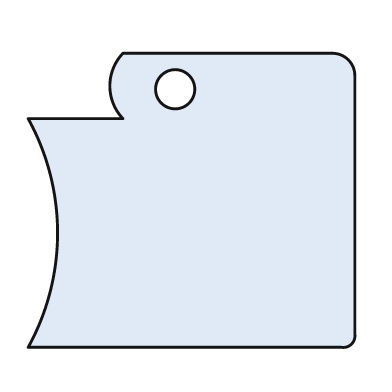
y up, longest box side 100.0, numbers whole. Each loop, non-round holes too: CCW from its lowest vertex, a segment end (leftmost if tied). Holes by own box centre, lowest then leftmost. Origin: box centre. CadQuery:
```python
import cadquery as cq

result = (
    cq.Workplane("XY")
    .moveTo(-50.0, -45.0)
    .lineTo(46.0, -45.0)
    .threePointArc((49.0, -44.0), (50.0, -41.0))
    .lineTo(50.0, 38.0)
    .threePointArc((48.0, 43.0), (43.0, 45.0))
    .lineTo(-21.0, 45.0)
    .threePointArc((-25.0, 35.0), (-21.0, 25.0))
    .lineTo(-50.0, 25.0)
    .threePointArc((-41.0, -10.0), (-50.0, -45.0))
    .close()
    .moveTo(-5.0, 34.0)
    .circle(6.0)
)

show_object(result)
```